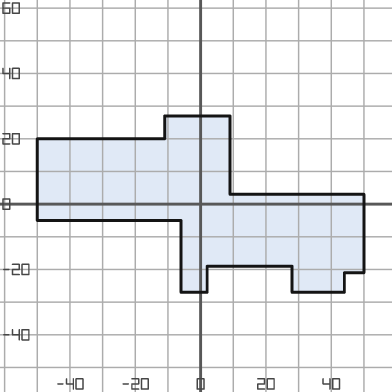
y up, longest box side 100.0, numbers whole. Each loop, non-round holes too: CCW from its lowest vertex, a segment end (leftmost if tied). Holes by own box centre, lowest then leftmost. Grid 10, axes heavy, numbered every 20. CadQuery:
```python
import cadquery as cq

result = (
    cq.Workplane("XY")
    .moveTo(-6.0, -27.0)
    .lineTo(2.0, -27.0)
    .lineTo(2.0, -19.0)
    .lineTo(28.0, -19.0)
    .lineTo(28.0, -27.0)
    .lineTo(44.0, -27.0)
    .lineTo(44.0, -21.0)
    .lineTo(50.0, -21.0)
    .lineTo(50.0, 3.0)
    .lineTo(9.0, 3.0)
    .lineTo(9.0, 27.0)
    .lineTo(-11.0, 27.0)
    .lineTo(-11.0, 20.0)
    .lineTo(-50.0, 20.0)
    .lineTo(-50.0, -5.0)
    .lineTo(-6.0, -5.0)
    .close()
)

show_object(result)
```